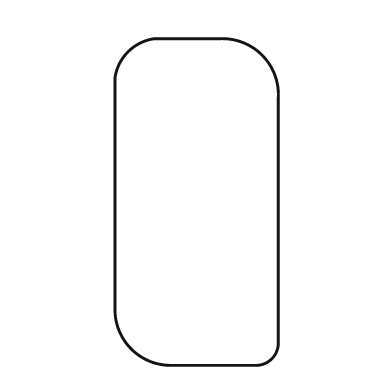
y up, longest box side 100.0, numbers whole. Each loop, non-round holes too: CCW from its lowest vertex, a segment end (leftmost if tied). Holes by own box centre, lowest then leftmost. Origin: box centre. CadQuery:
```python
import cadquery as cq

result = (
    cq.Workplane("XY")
    .moveTo(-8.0, -50.0)
    .lineTo(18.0, -50.0)
    .threePointArc((23.0, -48.0), (25.0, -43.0))
    .lineTo(25.0, 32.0)
    .threePointArc((20.0, 45.0), (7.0, 50.0))
    .lineTo(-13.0, 50.0)
    .threePointArc((-21.0, 46.0), (-25.0, 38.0))
    .lineTo(-25.0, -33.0)
    .threePointArc((-20.0, -45.0), (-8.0, -50.0))
    .close()
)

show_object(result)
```